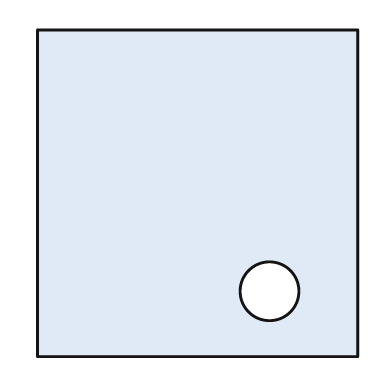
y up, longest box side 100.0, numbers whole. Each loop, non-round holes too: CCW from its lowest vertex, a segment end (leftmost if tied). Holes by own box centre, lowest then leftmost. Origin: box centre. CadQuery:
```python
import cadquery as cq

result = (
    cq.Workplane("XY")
    .moveTo(-49.0, -50.0)
    .lineTo(49.0, -50.0)
    .lineTo(49.0, 50.0)
    .lineTo(-49.0, 50.0)
    .close()
    .moveTo(22.0, -30.0)
    .circle(9.0)
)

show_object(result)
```